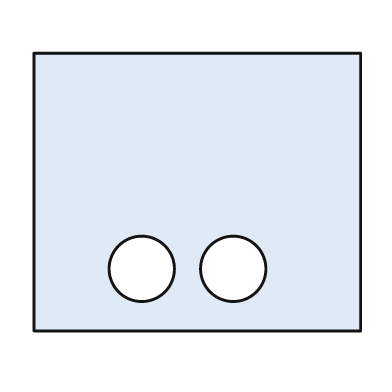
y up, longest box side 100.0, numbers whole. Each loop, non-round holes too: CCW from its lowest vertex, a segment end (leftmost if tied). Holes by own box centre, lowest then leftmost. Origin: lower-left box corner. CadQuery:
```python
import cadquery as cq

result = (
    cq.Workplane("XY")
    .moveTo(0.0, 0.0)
    .lineTo(100.0, 0.0)
    .lineTo(100.0, 85.0)
    .lineTo(0.0, 85.0)
    .close()
    .moveTo(33.0, 19.0)
    .circle(10.0)
    .moveTo(61.0, 19.0)
    .circle(10.0)
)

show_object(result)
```